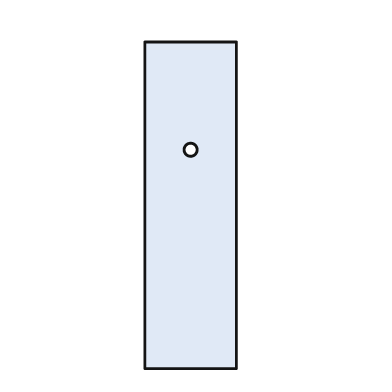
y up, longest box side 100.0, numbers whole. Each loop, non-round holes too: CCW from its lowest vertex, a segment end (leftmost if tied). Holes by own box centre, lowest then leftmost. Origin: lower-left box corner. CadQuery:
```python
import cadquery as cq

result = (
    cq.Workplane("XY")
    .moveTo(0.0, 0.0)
    .lineTo(28.0, 0.0)
    .lineTo(28.0, 100.0)
    .lineTo(0.0, 100.0)
    .close()
    .moveTo(14.0, 67.0)
    .circle(2.0)
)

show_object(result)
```